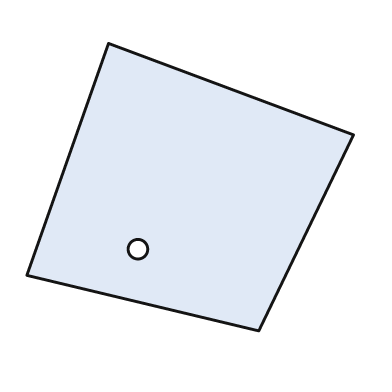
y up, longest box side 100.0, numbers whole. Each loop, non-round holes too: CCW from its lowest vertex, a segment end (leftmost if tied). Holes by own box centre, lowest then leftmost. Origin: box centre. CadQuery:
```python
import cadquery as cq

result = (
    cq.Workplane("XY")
    .moveTo(21.0, -44.0)
    .lineTo(50.0, 16.0)
    .lineTo(-25.0, 44.0)
    .lineTo(-50.0, -27.0)
    .close()
    .moveTo(-16.0, -19.0)
    .circle(3.0)
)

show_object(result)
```